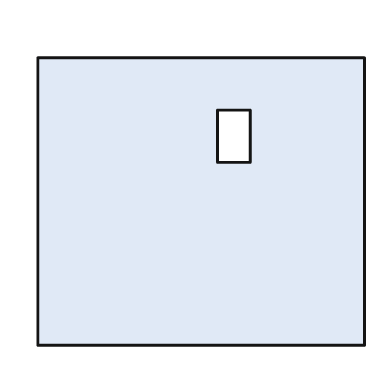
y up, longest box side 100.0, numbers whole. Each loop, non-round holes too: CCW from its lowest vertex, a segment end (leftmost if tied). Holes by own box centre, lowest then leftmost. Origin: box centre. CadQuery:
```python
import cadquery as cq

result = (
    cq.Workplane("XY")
    .moveTo(-50.0, -44.0)
    .lineTo(50.0, -44.0)
    .lineTo(50.0, 44.0)
    .lineTo(-50.0, 44.0)
    .close()
    .moveTo(5.0, 12.0)
    .lineTo(15.0, 12.0)
    .lineTo(15.0, 28.0)
    .lineTo(5.0, 28.0)
    .close()
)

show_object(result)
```